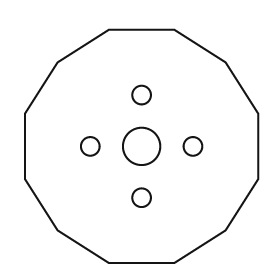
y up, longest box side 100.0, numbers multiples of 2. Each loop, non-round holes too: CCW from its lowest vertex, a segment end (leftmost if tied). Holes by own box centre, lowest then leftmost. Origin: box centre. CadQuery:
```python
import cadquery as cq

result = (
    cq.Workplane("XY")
    .moveTo(-14.0, -50.0)
    .lineTo(14.0, -50.0)
    .lineTo(36.0, -36.0)
    .lineTo(50.0, -14.0)
    .lineTo(50.0, 14.0)
    .lineTo(36.0, 36.0)
    .lineTo(14.0, 50.0)
    .lineTo(-14.0, 50.0)
    .lineTo(-36.0, 36.0)
    .lineTo(-50.0, 14.0)
    .lineTo(-50.0, -14.0)
    .lineTo(-36.0, -36.0)
    .close()
    .moveTo(0.0, -22.0)
    .circle(4.0)
    .moveTo(-22.0, 0.0)
    .circle(4.0)
    .moveTo(0.0, 0.0)
    .circle(8.0)
    .moveTo(22.0, 0.0)
    .circle(4.0)
    .moveTo(0.0, 22.0)
    .circle(4.0)
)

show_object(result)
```